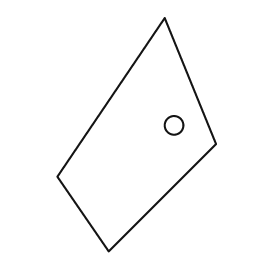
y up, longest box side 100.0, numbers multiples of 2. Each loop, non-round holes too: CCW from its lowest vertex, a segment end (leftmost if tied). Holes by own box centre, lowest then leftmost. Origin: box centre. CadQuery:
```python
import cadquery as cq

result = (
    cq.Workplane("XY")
    .moveTo(-12.0, -50.0)
    .lineTo(34.0, -4.0)
    .lineTo(12.0, 50.0)
    .lineTo(-34.0, -18.0)
    .close()
    .moveTo(16.0, 4.0)
    .circle(4.0)
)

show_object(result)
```